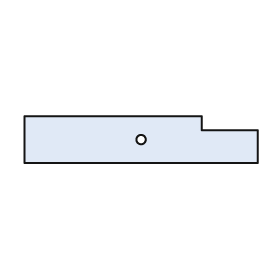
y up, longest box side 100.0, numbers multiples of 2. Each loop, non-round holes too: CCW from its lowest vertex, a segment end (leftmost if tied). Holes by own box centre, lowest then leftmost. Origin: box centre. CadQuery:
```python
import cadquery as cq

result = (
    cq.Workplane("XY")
    .moveTo(-50.0, -10.0)
    .lineTo(50.0, -10.0)
    .lineTo(50.0, 4.0)
    .lineTo(26.0, 4.0)
    .lineTo(26.0, 10.0)
    .lineTo(-50.0, 10.0)
    .close()
    .moveTo(0.0, 0.0)
    .circle(2.0)
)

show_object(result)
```